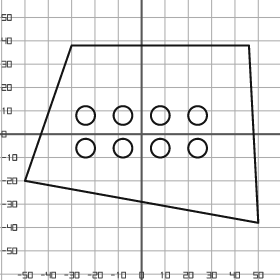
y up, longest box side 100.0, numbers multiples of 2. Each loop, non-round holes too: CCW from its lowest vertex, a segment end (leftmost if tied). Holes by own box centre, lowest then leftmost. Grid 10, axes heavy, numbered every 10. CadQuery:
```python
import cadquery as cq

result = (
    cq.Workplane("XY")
    .moveTo(50.0, -38.0)
    .lineTo(46.0, 38.0)
    .lineTo(-30.0, 38.0)
    .lineTo(-50.0, -20.0)
    .close()
    .moveTo(-24.0, -6.0)
    .circle(4.0)
    .moveTo(-8.0, -6.0)
    .circle(4.0)
    .moveTo(8.0, -6.0)
    .circle(4.0)
    .moveTo(24.0, -6.0)
    .circle(4.0)
    .moveTo(-24.0, 8.0)
    .circle(4.0)
    .moveTo(-8.0, 8.0)
    .circle(4.0)
    .moveTo(8.0, 8.0)
    .circle(4.0)
    .moveTo(24.0, 8.0)
    .circle(4.0)
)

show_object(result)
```